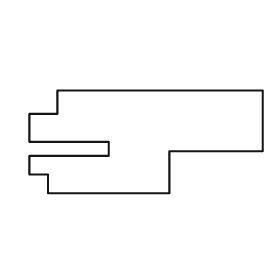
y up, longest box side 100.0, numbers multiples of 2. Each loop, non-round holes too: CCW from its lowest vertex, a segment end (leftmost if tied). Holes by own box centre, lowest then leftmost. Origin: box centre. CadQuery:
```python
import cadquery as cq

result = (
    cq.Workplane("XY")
    .moveTo(-42.0, -22.0)
    .lineTo(10.0, -22.0)
    .lineTo(10.0, -4.0)
    .lineTo(50.0, -4.0)
    .lineTo(50.0, 22.0)
    .lineTo(-38.0, 22.0)
    .lineTo(-38.0, 12.0)
    .lineTo(-50.0, 12.0)
    .lineTo(-50.0, 0.0)
    .lineTo(-16.0, 0.0)
    .lineTo(-16.0, -6.0)
    .lineTo(-50.0, -6.0)
    .lineTo(-50.0, -14.0)
    .lineTo(-42.0, -14.0)
    .close()
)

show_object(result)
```